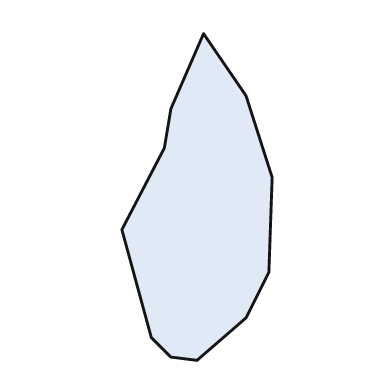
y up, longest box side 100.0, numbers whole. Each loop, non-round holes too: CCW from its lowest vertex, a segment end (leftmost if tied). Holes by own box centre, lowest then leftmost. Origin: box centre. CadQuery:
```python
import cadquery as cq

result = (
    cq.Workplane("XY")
    .moveTo(0.0, -50.0)
    .lineTo(15.0, -37.0)
    .lineTo(22.0, -23.0)
    .lineTo(23.0, 6.0)
    .lineTo(15.0, 31.0)
    .lineTo(2.0, 50.0)
    .lineTo(-8.0, 27.0)
    .lineTo(-10.0, 15.0)
    .lineTo(-23.0, -10.0)
    .lineTo(-14.0, -43.0)
    .lineTo(-8.0, -49.0)
    .close()
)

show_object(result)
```